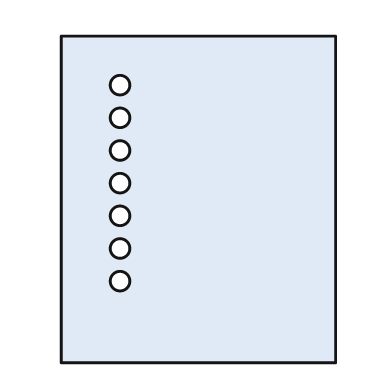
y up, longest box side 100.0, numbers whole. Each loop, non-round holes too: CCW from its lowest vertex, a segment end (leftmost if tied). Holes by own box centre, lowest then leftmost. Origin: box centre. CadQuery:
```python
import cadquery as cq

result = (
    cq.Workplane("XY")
    .moveTo(-42.0, -50.0)
    .lineTo(42.0, -50.0)
    .lineTo(42.0, 50.0)
    .lineTo(-42.0, 50.0)
    .close()
    .moveTo(-24.0, -25.0)
    .circle(3.0)
    .moveTo(-24.0, -15.0)
    .circle(3.0)
    .moveTo(-24.0, -5.0)
    .circle(3.0)
    .moveTo(-24.0, 5.0)
    .circle(3.0)
    .moveTo(-24.0, 15.0)
    .circle(3.0)
    .moveTo(-24.0, 25.0)
    .circle(3.0)
    .moveTo(-24.0, 35.0)
    .circle(3.0)
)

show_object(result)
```